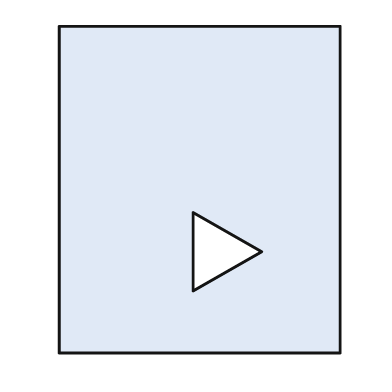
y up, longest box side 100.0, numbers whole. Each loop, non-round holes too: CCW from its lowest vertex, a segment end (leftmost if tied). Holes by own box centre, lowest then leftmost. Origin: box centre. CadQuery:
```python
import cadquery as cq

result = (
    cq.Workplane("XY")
    .moveTo(-43.0, -50.0)
    .lineTo(43.0, -50.0)
    .lineTo(43.0, 50.0)
    .lineTo(-43.0, 50.0)
    .close()
    .moveTo(-2.0, -31.0)
    .lineTo(19.0, -19.0)
    .lineTo(-2.0, -7.0)
    .close()
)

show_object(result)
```